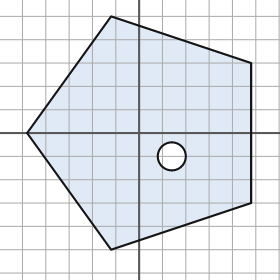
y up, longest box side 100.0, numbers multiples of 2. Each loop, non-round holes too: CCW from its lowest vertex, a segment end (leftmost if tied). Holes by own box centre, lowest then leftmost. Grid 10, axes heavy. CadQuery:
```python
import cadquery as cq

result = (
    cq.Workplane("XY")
    .moveTo(-12.0, -50.0)
    .lineTo(48.0, -30.0)
    .lineTo(48.0, 30.0)
    .lineTo(-12.0, 50.0)
    .lineTo(-48.0, 0.0)
    .close()
    .moveTo(14.0, -10.0)
    .circle(6.0)
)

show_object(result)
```